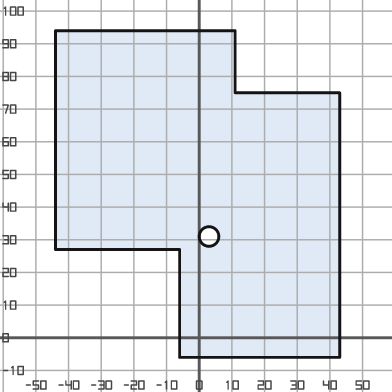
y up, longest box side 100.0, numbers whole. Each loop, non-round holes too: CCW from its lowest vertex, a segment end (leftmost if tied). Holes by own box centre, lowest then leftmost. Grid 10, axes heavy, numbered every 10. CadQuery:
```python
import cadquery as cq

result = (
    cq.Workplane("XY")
    .moveTo(-6.0, -6.0)
    .lineTo(43.0, -6.0)
    .lineTo(43.0, 75.0)
    .lineTo(11.0, 75.0)
    .lineTo(11.0, 94.0)
    .lineTo(-44.0, 94.0)
    .lineTo(-44.0, 27.0)
    .lineTo(-6.0, 27.0)
    .close()
    .moveTo(3.0, 31.0)
    .circle(3.0)
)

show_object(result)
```